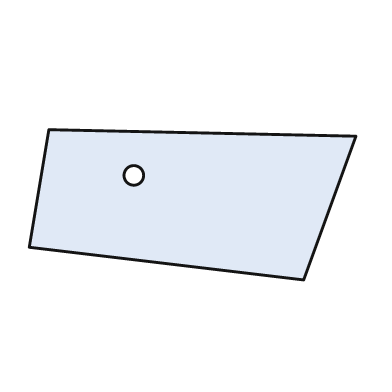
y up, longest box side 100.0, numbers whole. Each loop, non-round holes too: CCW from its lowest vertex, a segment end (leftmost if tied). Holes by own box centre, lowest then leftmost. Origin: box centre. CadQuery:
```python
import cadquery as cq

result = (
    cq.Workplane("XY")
    .moveTo(34.0, -23.0)
    .lineTo(50.0, 21.0)
    .lineTo(-44.0, 23.0)
    .lineTo(-50.0, -13.0)
    .close()
    .moveTo(-18.0, 9.0)
    .circle(3.0)
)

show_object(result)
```